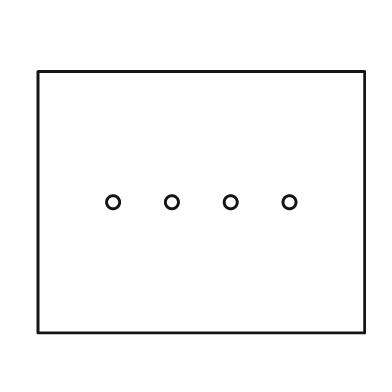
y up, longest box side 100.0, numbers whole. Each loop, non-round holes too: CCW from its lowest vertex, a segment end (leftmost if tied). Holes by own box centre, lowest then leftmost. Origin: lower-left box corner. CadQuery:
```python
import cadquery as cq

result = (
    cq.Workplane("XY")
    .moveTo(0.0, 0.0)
    .lineTo(100.0, 0.0)
    .lineTo(100.0, 80.0)
    .lineTo(0.0, 80.0)
    .close()
    .moveTo(23.0, 40.0)
    .circle(2.0)
    .moveTo(41.0, 40.0)
    .circle(2.0)
    .moveTo(59.0, 40.0)
    .circle(2.0)
    .moveTo(77.0, 40.0)
    .circle(2.0)
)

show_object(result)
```